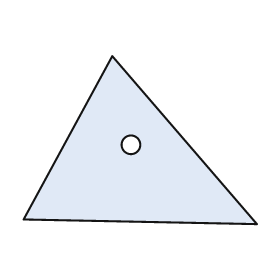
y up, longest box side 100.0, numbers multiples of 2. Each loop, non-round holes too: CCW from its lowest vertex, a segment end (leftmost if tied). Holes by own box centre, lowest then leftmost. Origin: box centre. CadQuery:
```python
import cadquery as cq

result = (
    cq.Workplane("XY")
    .moveTo(50.0, -36.0)
    .lineTo(-12.0, 36.0)
    .lineTo(-50.0, -34.0)
    .close()
    .moveTo(-4.0, -2.0)
    .circle(4.0)
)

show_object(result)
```